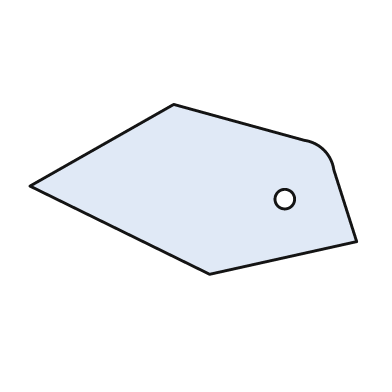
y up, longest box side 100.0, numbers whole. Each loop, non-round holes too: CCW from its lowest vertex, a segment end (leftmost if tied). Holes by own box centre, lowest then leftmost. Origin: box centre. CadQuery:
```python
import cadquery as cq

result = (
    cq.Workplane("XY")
    .moveTo(5.0, -26.0)
    .lineTo(50.0, -16.0)
    .lineTo(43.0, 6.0)
    .threePointArc((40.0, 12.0), (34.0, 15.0))
    .lineTo(-6.0, 26.0)
    .lineTo(-50.0, 1.0)
    .close()
    .moveTo(28.0, -3.0)
    .circle(3.0)
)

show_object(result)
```